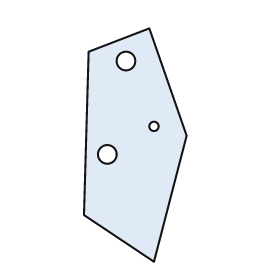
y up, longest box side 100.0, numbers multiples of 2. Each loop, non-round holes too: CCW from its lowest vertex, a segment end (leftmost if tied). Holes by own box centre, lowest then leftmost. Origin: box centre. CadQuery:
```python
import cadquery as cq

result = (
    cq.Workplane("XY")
    .moveTo(8.0, -50.0)
    .lineTo(22.0, 4.0)
    .lineTo(6.0, 50.0)
    .lineTo(-20.0, 40.0)
    .lineTo(-22.0, -30.0)
    .close()
    .moveTo(-12.0, -4.0)
    .circle(4.0)
    .moveTo(8.0, 8.0)
    .circle(2.0)
    .moveTo(-4.0, 36.0)
    .circle(4.0)
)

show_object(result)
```